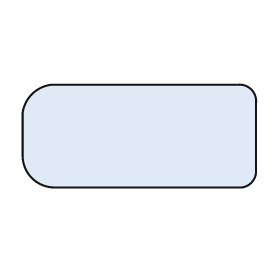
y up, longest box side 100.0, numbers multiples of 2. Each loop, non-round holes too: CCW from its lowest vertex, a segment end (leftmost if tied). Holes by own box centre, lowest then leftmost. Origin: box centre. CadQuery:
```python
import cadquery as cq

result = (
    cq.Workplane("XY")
    .moveTo(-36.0, -22.0)
    .lineTo(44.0, -22.0)
    .threePointArc((48.0, -20.0), (50.0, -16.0))
    .lineTo(50.0, 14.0)
    .threePointArc((48.0, 20.0), (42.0, 22.0))
    .lineTo(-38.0, 22.0)
    .threePointArc((-46.0, 18.0), (-50.0, 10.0))
    .lineTo(-50.0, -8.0)
    .threePointArc((-46.0, -18.0), (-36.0, -22.0))
    .close()
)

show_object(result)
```